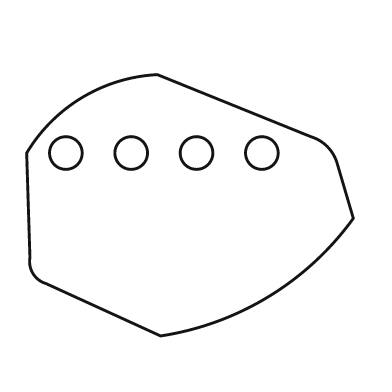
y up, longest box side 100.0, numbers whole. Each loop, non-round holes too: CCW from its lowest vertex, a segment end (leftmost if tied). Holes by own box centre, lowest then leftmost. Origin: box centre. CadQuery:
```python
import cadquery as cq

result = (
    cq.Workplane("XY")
    .moveTo(-9.0, -40.0)
    .threePointArc((24.0, -28.0), (50.0, -4.0))
    .lineTo(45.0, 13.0)
    .threePointArc((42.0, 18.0), (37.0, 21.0))
    .lineTo(-10.0, 40.0)
    .threePointArc((-33.0, 33.0), (-50.0, 16.0))
    .lineTo(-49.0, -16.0)
    .threePointArc((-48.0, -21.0), (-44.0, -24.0))
    .close()
    .moveTo(-38.0, 16.0)
    .circle(5.0)
    .moveTo(-18.0, 16.0)
    .circle(5.0)
    .moveTo(2.0, 16.0)
    .circle(5.0)
    .moveTo(22.0, 16.0)
    .circle(5.0)
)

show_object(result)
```